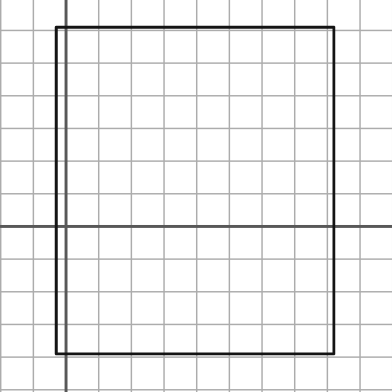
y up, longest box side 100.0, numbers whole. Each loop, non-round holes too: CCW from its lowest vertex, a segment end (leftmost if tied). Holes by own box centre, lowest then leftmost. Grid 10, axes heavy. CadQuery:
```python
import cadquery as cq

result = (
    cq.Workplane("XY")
    .moveTo(-3.0, -39.0)
    .lineTo(82.0, -39.0)
    .lineTo(82.0, 61.0)
    .lineTo(-3.0, 61.0)
    .close()
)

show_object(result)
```